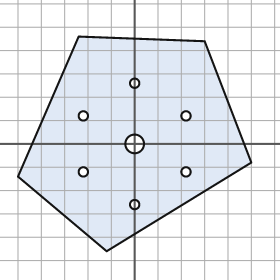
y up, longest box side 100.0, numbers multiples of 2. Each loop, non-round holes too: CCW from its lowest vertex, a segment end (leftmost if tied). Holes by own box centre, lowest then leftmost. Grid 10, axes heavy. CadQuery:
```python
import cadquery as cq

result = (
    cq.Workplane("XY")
    .moveTo(-12.0, -46.0)
    .lineTo(50.0, -8.0)
    .lineTo(30.0, 44.0)
    .lineTo(-24.0, 46.0)
    .lineTo(-50.0, -14.0)
    .close()
    .moveTo(0.0, -26.0)
    .circle(2.0)
    .moveTo(-22.0, -12.0)
    .circle(2.0)
    .moveTo(22.0, -12.0)
    .circle(2.0)
    .moveTo(0.0, 0.0)
    .circle(4.0)
    .moveTo(-22.0, 12.0)
    .circle(2.0)
    .moveTo(22.0, 12.0)
    .circle(2.0)
    .moveTo(0.0, 26.0)
    .circle(2.0)
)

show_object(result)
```